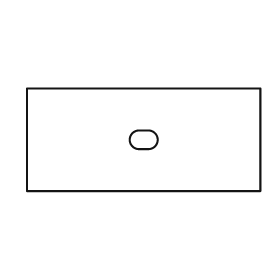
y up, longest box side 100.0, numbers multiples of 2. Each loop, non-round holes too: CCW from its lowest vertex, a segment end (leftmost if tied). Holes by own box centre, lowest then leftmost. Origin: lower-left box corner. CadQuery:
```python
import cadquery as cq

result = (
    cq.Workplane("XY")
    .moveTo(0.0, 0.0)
    .lineTo(100.0, 0.0)
    .lineTo(100.0, 44.0)
    .lineTo(0.0, 44.0)
    .close()
    .moveTo(48.0, 18.0)
    .lineTo(52.0, 18.0)
    .threePointArc((56.0, 22.0), (52.0, 26.0))
    .lineTo(48.0, 26.0)
    .threePointArc((44.0, 22.0), (48.0, 18.0))
    .close()
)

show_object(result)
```